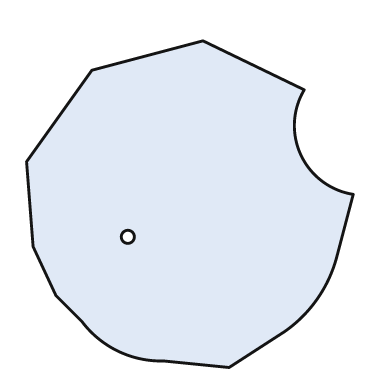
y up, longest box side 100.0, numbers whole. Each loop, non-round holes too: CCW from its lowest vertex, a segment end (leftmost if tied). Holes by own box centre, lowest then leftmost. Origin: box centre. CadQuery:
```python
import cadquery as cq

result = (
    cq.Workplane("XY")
    .moveTo(12.0, -50.0)
    .lineTo(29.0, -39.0)
    .threePointArc((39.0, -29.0), (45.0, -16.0))
    .lineTo(50.0, 3.0)
    .threePointArc((34.0, 15.0), (35.0, 35.0))
    .lineTo(4.0, 50.0)
    .lineTo(-30.0, 41.0)
    .lineTo(-50.0, 13.0)
    .lineTo(-48.0, -13.0)
    .lineTo(-41.0, -28.0)
    .lineTo(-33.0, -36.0)
    .threePointArc((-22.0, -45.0), (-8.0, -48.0))
    .close()
    .moveTo(-19.0, -10.0)
    .circle(2.0)
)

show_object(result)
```